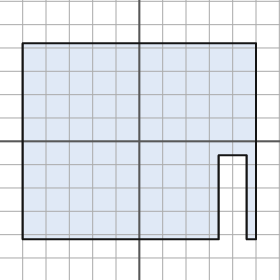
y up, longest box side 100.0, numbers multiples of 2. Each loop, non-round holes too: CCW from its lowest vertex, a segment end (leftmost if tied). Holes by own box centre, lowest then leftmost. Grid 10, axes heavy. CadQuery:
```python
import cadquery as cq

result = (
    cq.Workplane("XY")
    .moveTo(-50.0, -42.0)
    .lineTo(34.0, -42.0)
    .lineTo(34.0, -6.0)
    .lineTo(46.0, -6.0)
    .lineTo(46.0, -42.0)
    .lineTo(50.0, -42.0)
    .lineTo(50.0, 42.0)
    .lineTo(-50.0, 42.0)
    .close()
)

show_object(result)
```